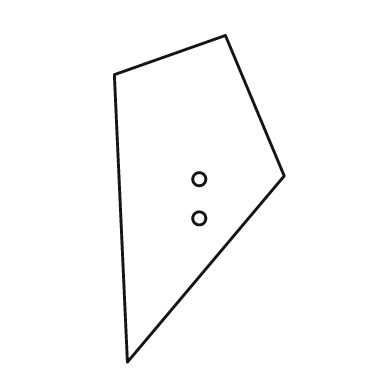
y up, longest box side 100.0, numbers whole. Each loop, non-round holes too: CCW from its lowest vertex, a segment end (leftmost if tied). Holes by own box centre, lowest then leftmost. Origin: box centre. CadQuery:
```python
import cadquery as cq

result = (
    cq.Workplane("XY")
    .moveTo(-22.0, -50.0)
    .lineTo(26.0, 7.0)
    .lineTo(8.0, 50.0)
    .lineTo(-26.0, 38.0)
    .close()
    .moveTo(0.0, -6.0)
    .circle(2.0)
    .moveTo(0.0, 6.0)
    .circle(2.0)
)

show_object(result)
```